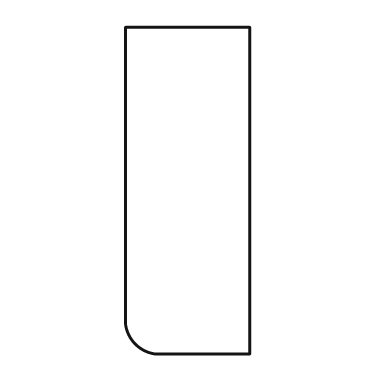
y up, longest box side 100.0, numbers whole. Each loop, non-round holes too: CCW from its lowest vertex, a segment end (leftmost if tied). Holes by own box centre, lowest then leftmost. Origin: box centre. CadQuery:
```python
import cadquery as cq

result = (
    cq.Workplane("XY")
    .moveTo(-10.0, -50.0)
    .lineTo(19.0, -50.0)
    .lineTo(19.0, 50.0)
    .lineTo(-19.0, 50.0)
    .lineTo(-19.0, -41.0)
    .threePointArc((-16.0, -47.0), (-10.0, -50.0))
    .close()
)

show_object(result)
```